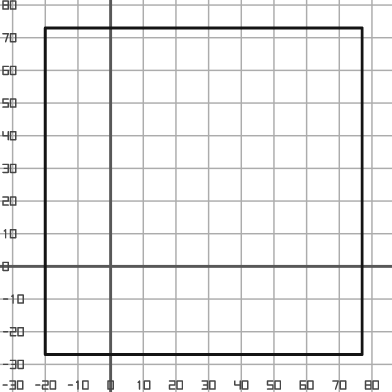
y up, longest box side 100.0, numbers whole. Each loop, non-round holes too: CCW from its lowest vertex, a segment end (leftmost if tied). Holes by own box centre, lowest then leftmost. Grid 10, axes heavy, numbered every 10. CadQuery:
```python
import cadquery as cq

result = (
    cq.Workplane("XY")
    .moveTo(-20.0, -27.0)
    .lineTo(77.0, -27.0)
    .lineTo(77.0, 73.0)
    .lineTo(-20.0, 73.0)
    .close()
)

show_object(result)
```